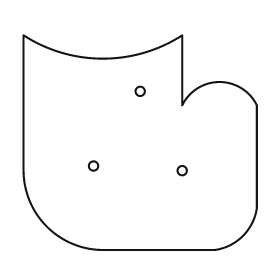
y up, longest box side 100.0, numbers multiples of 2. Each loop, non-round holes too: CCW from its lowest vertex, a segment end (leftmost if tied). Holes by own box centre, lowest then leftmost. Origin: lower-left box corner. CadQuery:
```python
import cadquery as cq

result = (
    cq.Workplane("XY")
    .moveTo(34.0, 0.0)
    .lineTo(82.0, 0.0)
    .threePointArc((94.0, 6.0), (100.0, 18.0))
    .lineTo(100.0, 62.0)
    .threePointArc((84.0, 72.0), (68.0, 62.0))
    .lineTo(68.0, 92.0)
    .threePointArc((34.0, 82.0), (0.0, 92.0))
    .lineTo(0.0, 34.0)
    .threePointArc((10.0, 10.0), (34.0, 0.0))
    .close()
    .moveTo(68.0, 34.0)
    .circle(2.0)
    .moveTo(30.0, 36.0)
    .circle(2.0)
    .moveTo(50.0, 68.0)
    .circle(2.0)
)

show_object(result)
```